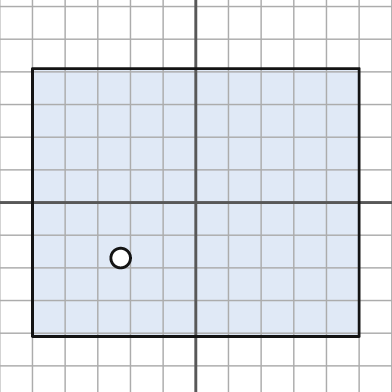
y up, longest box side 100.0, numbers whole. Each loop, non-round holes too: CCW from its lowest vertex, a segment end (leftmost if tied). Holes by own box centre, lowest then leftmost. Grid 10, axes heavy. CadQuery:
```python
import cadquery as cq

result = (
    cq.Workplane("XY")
    .moveTo(-50.0, -41.0)
    .lineTo(50.0, -41.0)
    .lineTo(50.0, 41.0)
    .lineTo(-50.0, 41.0)
    .close()
    .moveTo(-23.0, -17.0)
    .circle(3.0)
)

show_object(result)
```